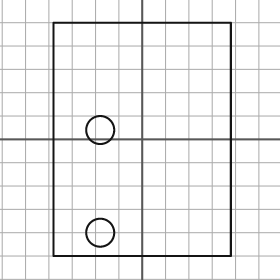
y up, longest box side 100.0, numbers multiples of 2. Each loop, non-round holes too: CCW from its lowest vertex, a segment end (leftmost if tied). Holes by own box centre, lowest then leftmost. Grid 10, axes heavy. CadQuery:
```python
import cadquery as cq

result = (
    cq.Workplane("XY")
    .moveTo(-38.0, -50.0)
    .lineTo(38.0, -50.0)
    .lineTo(38.0, 50.0)
    .lineTo(-38.0, 50.0)
    .close()
    .moveTo(-18.0, -40.0)
    .circle(6.0)
    .moveTo(-18.0, 4.0)
    .circle(6.0)
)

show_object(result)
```